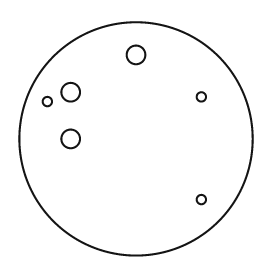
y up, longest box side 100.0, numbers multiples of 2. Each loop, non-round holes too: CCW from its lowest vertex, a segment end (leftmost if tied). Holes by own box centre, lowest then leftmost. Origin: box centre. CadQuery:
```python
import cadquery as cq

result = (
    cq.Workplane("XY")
    .moveTo(0.0, 0.0)
    .circle(50.0)
    .moveTo(28.0, -26.0)
    .circle(2.0)
    .moveTo(-28.0, 0.0)
    .circle(4.0)
    .moveTo(-38.0, 16.0)
    .circle(2.0)
    .moveTo(28.0, 18.0)
    .circle(2.0)
    .moveTo(-28.0, 20.0)
    .circle(4.0)
    .moveTo(0.0, 36.0)
    .circle(4.0)
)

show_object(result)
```